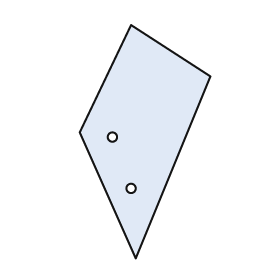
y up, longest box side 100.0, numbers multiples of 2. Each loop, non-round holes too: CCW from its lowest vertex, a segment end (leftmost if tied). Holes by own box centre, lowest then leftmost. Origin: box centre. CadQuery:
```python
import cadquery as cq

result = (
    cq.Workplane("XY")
    .moveTo(-4.0, -50.0)
    .lineTo(28.0, 28.0)
    .lineTo(-6.0, 50.0)
    .lineTo(-28.0, 4.0)
    .close()
    .moveTo(-6.0, -20.0)
    .circle(2.0)
    .moveTo(-14.0, 2.0)
    .circle(2.0)
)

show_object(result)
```